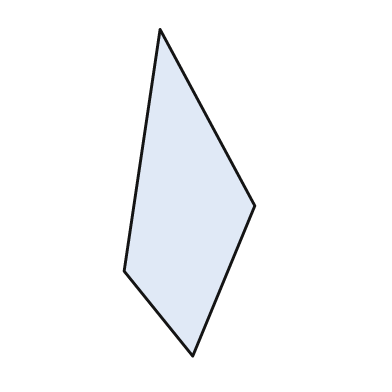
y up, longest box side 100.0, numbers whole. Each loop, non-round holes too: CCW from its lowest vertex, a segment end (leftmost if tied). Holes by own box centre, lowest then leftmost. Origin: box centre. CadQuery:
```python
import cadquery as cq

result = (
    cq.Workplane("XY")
    .moveTo(1.0, -50.0)
    .lineTo(20.0, -4.0)
    .lineTo(-9.0, 50.0)
    .lineTo(-20.0, -24.0)
    .close()
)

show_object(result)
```